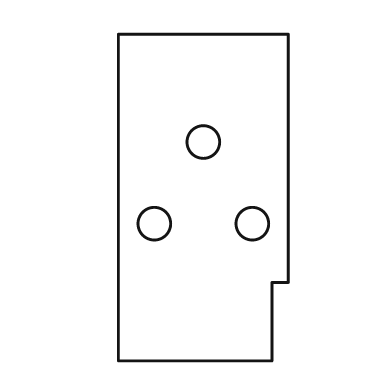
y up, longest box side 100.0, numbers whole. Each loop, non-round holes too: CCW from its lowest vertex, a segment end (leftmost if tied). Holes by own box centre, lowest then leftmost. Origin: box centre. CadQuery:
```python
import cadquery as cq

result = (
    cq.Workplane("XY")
    .moveTo(-26.0, -50.0)
    .lineTo(21.0, -50.0)
    .lineTo(21.0, -26.0)
    .lineTo(26.0, -26.0)
    .lineTo(26.0, 50.0)
    .lineTo(-26.0, 50.0)
    .close()
    .moveTo(-15.0, -8.0)
    .circle(5.0)
    .moveTo(15.0, -8.0)
    .circle(5.0)
    .moveTo(0.0, 17.0)
    .circle(5.0)
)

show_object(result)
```